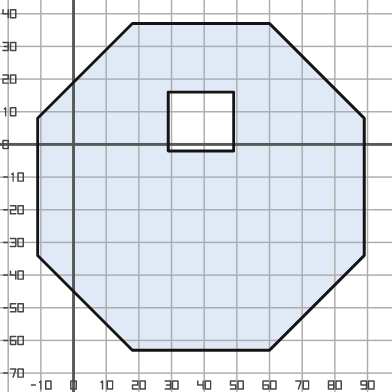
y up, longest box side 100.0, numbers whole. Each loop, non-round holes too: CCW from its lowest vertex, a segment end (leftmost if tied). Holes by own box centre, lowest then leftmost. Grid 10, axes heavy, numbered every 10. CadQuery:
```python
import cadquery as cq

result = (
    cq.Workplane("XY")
    .moveTo(18.0, -63.0)
    .lineTo(60.0, -63.0)
    .lineTo(89.0, -34.0)
    .lineTo(89.0, 8.0)
    .lineTo(60.0, 37.0)
    .lineTo(18.0, 37.0)
    .lineTo(-11.0, 8.0)
    .lineTo(-11.0, -34.0)
    .close()
    .moveTo(29.0, -2.0)
    .lineTo(49.0, -2.0)
    .lineTo(49.0, 16.0)
    .lineTo(29.0, 16.0)
    .close()
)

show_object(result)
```